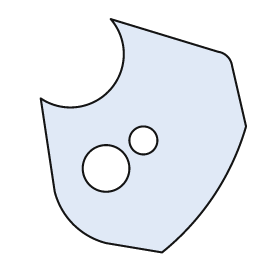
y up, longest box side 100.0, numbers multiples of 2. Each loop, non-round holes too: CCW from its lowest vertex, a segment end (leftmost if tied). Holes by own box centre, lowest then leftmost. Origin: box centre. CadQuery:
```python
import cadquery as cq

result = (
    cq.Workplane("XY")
    .moveTo(8.0, -50.0)
    .threePointArc((30.0, -26.0), (44.0, 4.0))
    .lineTo(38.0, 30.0)
    .threePointArc((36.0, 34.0), (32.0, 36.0))
    .lineTo(-14.0, 50.0)
    .threePointArc((-14.0, 20.0), (-44.0, 16.0))
    .lineTo(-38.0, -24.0)
    .threePointArc((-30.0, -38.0), (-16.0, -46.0))
    .close()
    .moveTo(-16.0, -14.0)
    .circle(10.0)
    .moveTo(0.0, -2.0)
    .circle(6.0)
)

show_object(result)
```